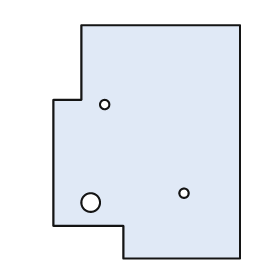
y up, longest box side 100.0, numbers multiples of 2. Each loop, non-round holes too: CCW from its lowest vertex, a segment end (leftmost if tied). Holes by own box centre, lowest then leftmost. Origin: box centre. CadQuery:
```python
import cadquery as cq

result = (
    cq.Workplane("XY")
    .moveTo(-10.0, -50.0)
    .lineTo(40.0, -50.0)
    .lineTo(40.0, 50.0)
    .lineTo(-28.0, 50.0)
    .lineTo(-28.0, 18.0)
    .lineTo(-40.0, 18.0)
    .lineTo(-40.0, -36.0)
    .lineTo(-10.0, -36.0)
    .close()
    .moveTo(-24.0, -26.0)
    .circle(4.0)
    .moveTo(16.0, -22.0)
    .circle(2.0)
    .moveTo(-18.0, 16.0)
    .circle(2.0)
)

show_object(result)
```